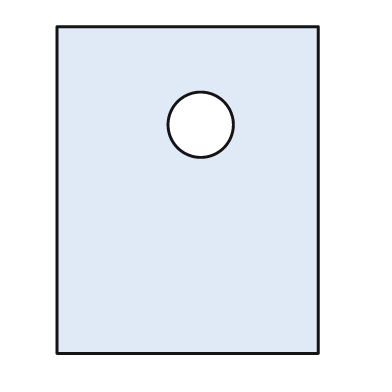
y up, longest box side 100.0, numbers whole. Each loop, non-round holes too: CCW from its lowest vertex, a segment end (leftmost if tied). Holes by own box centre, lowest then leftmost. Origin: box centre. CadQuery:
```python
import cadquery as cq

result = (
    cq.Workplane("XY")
    .moveTo(-40.0, -50.0)
    .lineTo(40.0, -50.0)
    .lineTo(40.0, 50.0)
    .lineTo(-40.0, 50.0)
    .close()
    .moveTo(4.0, 20.0)
    .circle(10.0)
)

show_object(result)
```